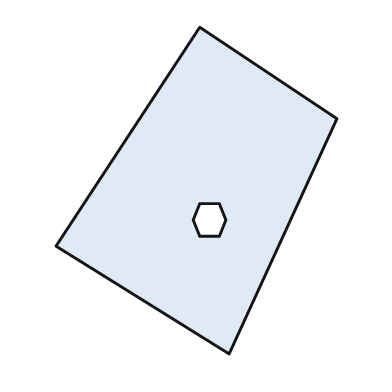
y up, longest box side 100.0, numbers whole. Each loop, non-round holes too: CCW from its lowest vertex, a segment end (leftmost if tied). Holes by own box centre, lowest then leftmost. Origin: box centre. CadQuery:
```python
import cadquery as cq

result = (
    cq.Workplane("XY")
    .moveTo(10.0, -50.0)
    .lineTo(43.0, 22.0)
    .lineTo(1.0, 50.0)
    .lineTo(-43.0, -17.0)
    .close()
    .moveTo(1.0, -14.0)
    .lineTo(7.0, -14.0)
    .lineTo(9.0, -9.0)
    .lineTo(7.0, -4.0)
    .lineTo(1.0, -4.0)
    .lineTo(-1.0, -9.0)
    .close()
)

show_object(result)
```